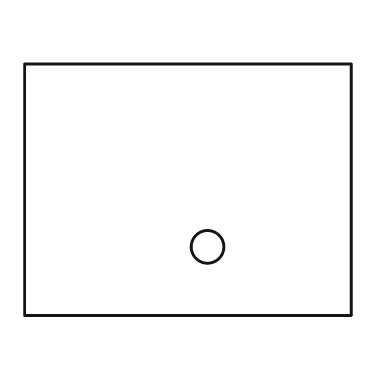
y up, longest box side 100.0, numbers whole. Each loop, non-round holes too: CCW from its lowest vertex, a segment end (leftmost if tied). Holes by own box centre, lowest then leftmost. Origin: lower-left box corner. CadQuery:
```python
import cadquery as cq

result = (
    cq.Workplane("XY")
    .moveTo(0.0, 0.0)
    .lineTo(100.0, 0.0)
    .lineTo(100.0, 77.0)
    .lineTo(0.0, 77.0)
    .close()
    .moveTo(56.0, 21.0)
    .circle(5.0)
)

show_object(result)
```